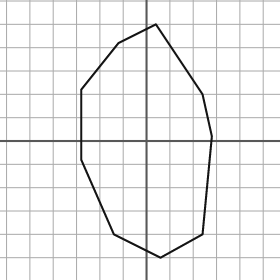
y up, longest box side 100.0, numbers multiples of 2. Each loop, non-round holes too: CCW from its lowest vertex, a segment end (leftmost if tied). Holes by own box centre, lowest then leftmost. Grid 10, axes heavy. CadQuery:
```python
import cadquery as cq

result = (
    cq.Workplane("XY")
    .moveTo(6.0, -50.0)
    .lineTo(24.0, -40.0)
    .lineTo(28.0, 2.0)
    .lineTo(24.0, 20.0)
    .lineTo(4.0, 50.0)
    .lineTo(-12.0, 42.0)
    .lineTo(-28.0, 22.0)
    .lineTo(-28.0, -8.0)
    .lineTo(-14.0, -40.0)
    .close()
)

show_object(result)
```